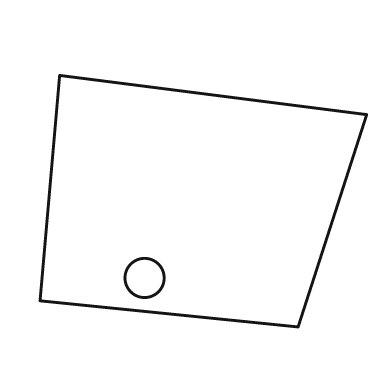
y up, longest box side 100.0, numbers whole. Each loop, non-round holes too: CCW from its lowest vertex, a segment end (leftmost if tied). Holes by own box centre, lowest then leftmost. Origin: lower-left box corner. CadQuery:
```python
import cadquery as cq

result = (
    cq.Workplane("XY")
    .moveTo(79.0, 0.0)
    .lineTo(100.0, 65.0)
    .lineTo(6.0, 77.0)
    .lineTo(0.0, 8.0)
    .close()
    .moveTo(32.0, 15.0)
    .circle(6.0)
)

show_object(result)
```